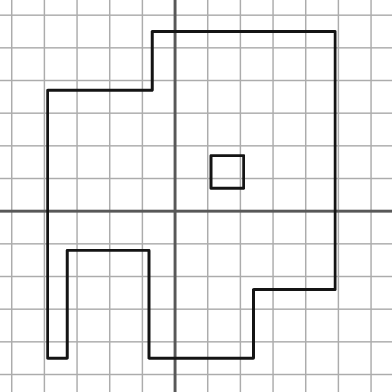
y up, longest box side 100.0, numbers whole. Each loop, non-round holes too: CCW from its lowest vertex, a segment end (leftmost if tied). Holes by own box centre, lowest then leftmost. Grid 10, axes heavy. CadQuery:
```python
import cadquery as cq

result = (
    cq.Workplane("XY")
    .moveTo(-39.0, -45.0)
    .lineTo(-33.0, -45.0)
    .lineTo(-33.0, -12.0)
    .lineTo(-8.0, -12.0)
    .lineTo(-8.0, -45.0)
    .lineTo(24.0, -45.0)
    .lineTo(24.0, -24.0)
    .lineTo(49.0, -24.0)
    .lineTo(49.0, 55.0)
    .lineTo(-7.0, 55.0)
    .lineTo(-7.0, 37.0)
    .lineTo(-39.0, 37.0)
    .close()
    .moveTo(11.0, 7.0)
    .lineTo(21.0, 7.0)
    .lineTo(21.0, 17.0)
    .lineTo(11.0, 17.0)
    .close()
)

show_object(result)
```